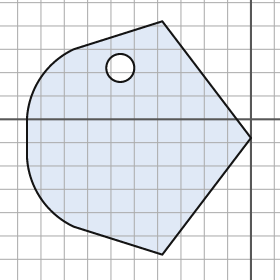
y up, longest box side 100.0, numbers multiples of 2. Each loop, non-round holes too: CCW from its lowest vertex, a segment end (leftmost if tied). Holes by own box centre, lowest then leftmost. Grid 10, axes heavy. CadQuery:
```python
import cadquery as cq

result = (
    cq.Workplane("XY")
    .moveTo(-38.0, -58.0)
    .lineTo(0.0, -8.0)
    .lineTo(-38.0, 42.0)
    .lineTo(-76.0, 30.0)
    .threePointArc((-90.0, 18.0), (-96.0, 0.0))
    .lineTo(-96.0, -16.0)
    .threePointArc((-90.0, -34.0), (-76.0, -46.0))
    .close()
    .moveTo(-56.0, 22.0)
    .circle(6.0)
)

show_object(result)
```